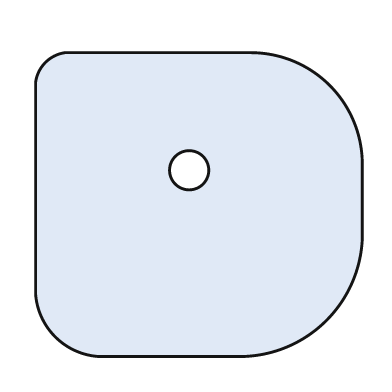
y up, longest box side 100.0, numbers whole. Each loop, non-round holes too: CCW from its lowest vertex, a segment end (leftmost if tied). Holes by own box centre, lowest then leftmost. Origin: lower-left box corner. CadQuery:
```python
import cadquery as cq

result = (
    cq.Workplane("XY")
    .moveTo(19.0, 0.0)
    .lineTo(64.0, 0.0)
    .threePointArc((89.0, 11.0), (100.0, 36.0))
    .lineTo(100.0, 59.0)
    .threePointArc((90.0, 83.0), (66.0, 93.0))
    .lineTo(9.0, 93.0)
    .threePointArc((3.0, 90.0), (0.0, 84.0))
    .lineTo(0.0, 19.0)
    .threePointArc((6.0, 6.0), (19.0, 0.0))
    .close()
    .moveTo(47.0, 57.0)
    .circle(6.0)
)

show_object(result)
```